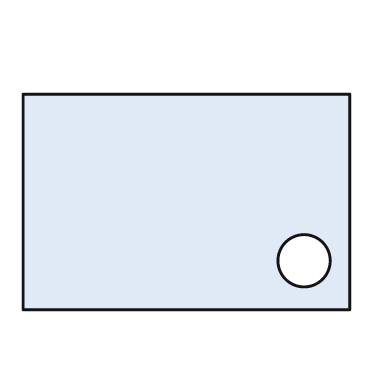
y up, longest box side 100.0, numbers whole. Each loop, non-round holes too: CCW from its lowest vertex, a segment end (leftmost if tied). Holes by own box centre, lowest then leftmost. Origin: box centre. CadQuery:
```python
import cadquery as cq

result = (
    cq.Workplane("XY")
    .moveTo(-50.0, -33.0)
    .lineTo(50.0, -33.0)
    .lineTo(50.0, 33.0)
    .lineTo(-50.0, 33.0)
    .close()
    .moveTo(36.0, -18.0)
    .circle(8.0)
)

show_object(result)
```